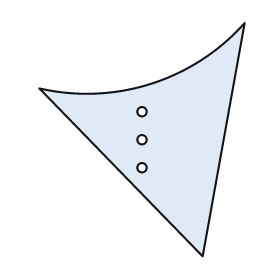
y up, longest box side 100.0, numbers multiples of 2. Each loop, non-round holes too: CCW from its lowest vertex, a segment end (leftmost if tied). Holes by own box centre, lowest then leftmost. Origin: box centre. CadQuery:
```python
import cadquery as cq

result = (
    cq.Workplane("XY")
    .moveTo(26.0, -50.0)
    .lineTo(44.0, 50.0)
    .threePointArc((4.0, 24.0), (-44.0, 22.0))
    .close()
    .moveTo(0.0, -12.0)
    .circle(2.0)
    .moveTo(0.0, 0.0)
    .circle(2.0)
    .moveTo(0.0, 12.0)
    .circle(2.0)
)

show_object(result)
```